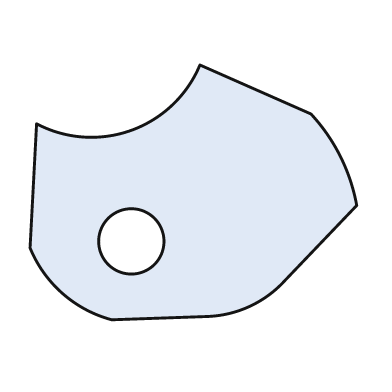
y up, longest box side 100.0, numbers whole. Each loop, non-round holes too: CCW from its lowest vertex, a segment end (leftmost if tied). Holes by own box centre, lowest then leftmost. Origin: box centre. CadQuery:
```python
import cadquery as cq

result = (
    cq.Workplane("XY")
    .moveTo(-25.0, -39.0)
    .lineTo(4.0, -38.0)
    .threePointArc((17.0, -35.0), (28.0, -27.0))
    .lineTo(50.0, -4.0)
    .threePointArc((45.0, 11.0), (36.0, 24.0))
    .lineTo(2.0, 39.0)
    .threePointArc((-19.0, 19.0), (-48.0, 21.0))
    .lineTo(-50.0, -17.0)
    .threePointArc((-40.0, -31.0), (-25.0, -39.0))
    .close()
    .moveTo(-19.0, -15.0)
    .circle(10.0)
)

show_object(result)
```